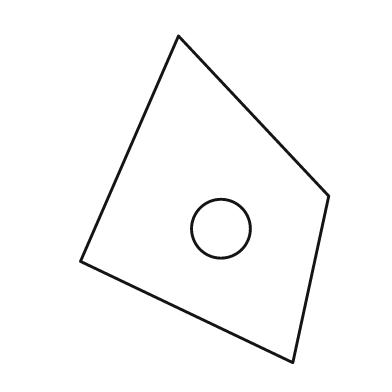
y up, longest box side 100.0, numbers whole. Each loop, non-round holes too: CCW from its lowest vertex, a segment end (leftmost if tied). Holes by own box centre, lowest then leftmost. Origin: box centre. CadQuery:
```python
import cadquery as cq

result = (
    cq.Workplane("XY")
    .moveTo(27.0, -50.0)
    .lineTo(38.0, 1.0)
    .lineTo(-8.0, 50.0)
    .lineTo(-38.0, -19.0)
    .close()
    .moveTo(5.0, -9.0)
    .circle(9.0)
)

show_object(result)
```